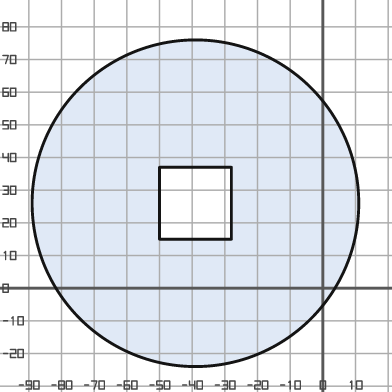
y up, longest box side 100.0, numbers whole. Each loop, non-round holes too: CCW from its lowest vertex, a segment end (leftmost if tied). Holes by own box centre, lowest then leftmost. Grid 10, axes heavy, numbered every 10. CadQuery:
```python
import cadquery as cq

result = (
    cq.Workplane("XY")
    .moveTo(-39.0, 26.0)
    .circle(50.0)
    .moveTo(-50.0, 15.0)
    .lineTo(-28.0, 15.0)
    .lineTo(-28.0, 37.0)
    .lineTo(-50.0, 37.0)
    .close()
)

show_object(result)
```